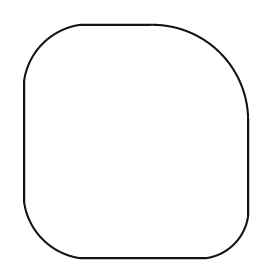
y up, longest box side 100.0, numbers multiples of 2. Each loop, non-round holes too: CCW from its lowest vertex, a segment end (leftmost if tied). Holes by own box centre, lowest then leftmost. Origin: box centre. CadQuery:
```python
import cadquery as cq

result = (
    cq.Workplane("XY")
    .moveTo(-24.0, -50.0)
    .lineTo(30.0, -50.0)
    .threePointArc((42.0, -44.0), (48.0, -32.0))
    .lineTo(48.0, 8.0)
    .threePointArc((36.0, 38.0), (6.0, 50.0))
    .lineTo(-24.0, 50.0)
    .threePointArc((-40.0, 42.0), (-48.0, 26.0))
    .lineTo(-48.0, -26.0)
    .threePointArc((-40.0, -42.0), (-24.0, -50.0))
    .close()
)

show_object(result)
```